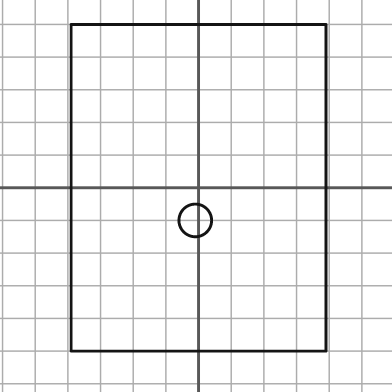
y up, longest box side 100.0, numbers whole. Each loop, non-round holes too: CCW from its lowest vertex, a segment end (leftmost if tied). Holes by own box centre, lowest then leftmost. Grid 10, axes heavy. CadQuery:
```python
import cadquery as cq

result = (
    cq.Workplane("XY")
    .moveTo(-39.0, -50.0)
    .lineTo(39.0, -50.0)
    .lineTo(39.0, 50.0)
    .lineTo(-39.0, 50.0)
    .close()
    .moveTo(-1.0, -10.0)
    .circle(5.0)
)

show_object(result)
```